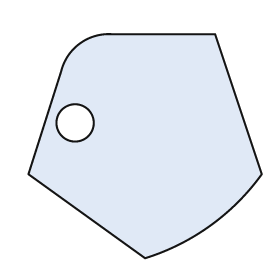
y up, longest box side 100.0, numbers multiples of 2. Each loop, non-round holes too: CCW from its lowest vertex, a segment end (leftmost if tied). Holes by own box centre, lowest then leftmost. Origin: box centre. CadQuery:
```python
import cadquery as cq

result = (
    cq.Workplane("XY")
    .moveTo(0.0, -48.0)
    .threePointArc((28.0, -34.0), (50.0, -12.0))
    .lineTo(30.0, 48.0)
    .lineTo(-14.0, 48.0)
    .threePointArc((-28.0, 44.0), (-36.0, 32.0))
    .lineTo(-50.0, -12.0)
    .close()
    .moveTo(-30.0, 10.0)
    .circle(8.0)
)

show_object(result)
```